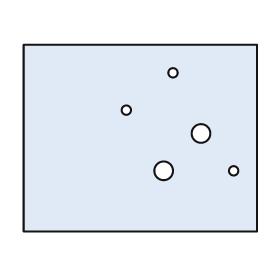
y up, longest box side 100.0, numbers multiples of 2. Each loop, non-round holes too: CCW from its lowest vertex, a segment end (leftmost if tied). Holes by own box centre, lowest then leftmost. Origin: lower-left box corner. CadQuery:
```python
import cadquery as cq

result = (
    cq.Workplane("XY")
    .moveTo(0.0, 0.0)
    .lineTo(100.0, 0.0)
    .lineTo(100.0, 80.0)
    .lineTo(0.0, 80.0)
    .close()
    .moveTo(60.0, 26.0)
    .circle(4.0)
    .moveTo(90.0, 26.0)
    .circle(2.0)
    .moveTo(76.0, 42.0)
    .circle(4.0)
    .moveTo(44.0, 52.0)
    .circle(2.0)
    .moveTo(64.0, 68.0)
    .circle(2.0)
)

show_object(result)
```